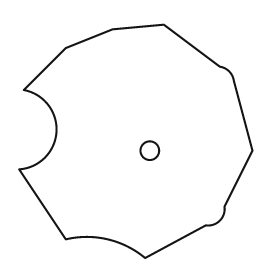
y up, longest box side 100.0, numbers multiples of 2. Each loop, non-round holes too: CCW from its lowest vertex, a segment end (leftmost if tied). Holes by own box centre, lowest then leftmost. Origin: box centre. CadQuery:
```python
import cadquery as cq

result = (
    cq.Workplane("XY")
    .moveTo(4.0, -50.0)
    .lineTo(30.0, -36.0)
    .threePointArc((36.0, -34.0), (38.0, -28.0))
    .lineTo(50.0, -4.0)
    .lineTo(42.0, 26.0)
    .threePointArc((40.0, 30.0), (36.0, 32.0))
    .lineTo(12.0, 50.0)
    .lineTo(-10.0, 48.0)
    .lineTo(-30.0, 40.0)
    .lineTo(-48.0, 22.0)
    .threePointArc((-34.0, 4.0), (-50.0, -12.0))
    .lineTo(-30.0, -42.0)
    .threePointArc((-12.0, -42.0), (4.0, -50.0))
    .close()
    .moveTo(6.0, -4.0)
    .circle(4.0)
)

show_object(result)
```